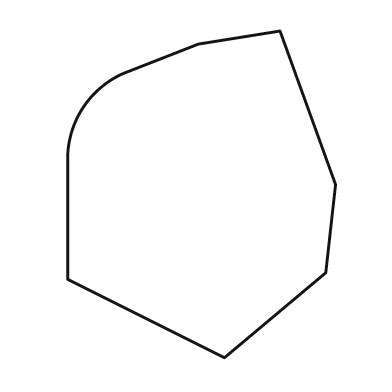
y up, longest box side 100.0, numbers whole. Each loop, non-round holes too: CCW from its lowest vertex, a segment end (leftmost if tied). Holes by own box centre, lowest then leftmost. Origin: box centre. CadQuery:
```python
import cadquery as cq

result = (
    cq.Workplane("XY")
    .moveTo(7.0, -50.0)
    .lineTo(38.0, -24.0)
    .lineTo(41.0, 3.0)
    .lineTo(24.0, 50.0)
    .lineTo(-1.0, 46.0)
    .lineTo(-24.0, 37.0)
    .threePointArc((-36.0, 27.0), (-41.0, 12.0))
    .lineTo(-41.0, -26.0)
    .close()
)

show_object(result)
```